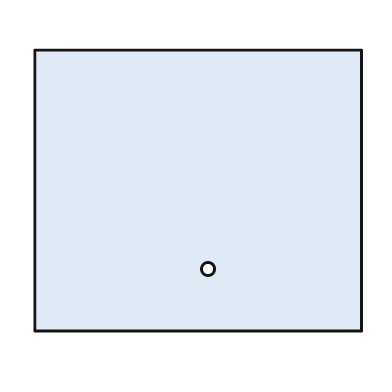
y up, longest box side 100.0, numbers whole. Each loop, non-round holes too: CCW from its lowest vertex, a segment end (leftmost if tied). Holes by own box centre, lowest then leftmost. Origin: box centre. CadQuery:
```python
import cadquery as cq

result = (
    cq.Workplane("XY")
    .moveTo(-50.0, -43.0)
    .lineTo(50.0, -43.0)
    .lineTo(50.0, 43.0)
    .lineTo(-50.0, 43.0)
    .close()
    .moveTo(3.0, -24.0)
    .circle(2.0)
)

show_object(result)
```